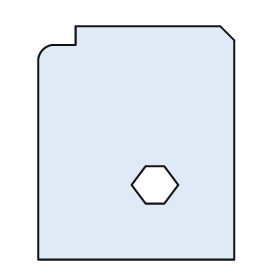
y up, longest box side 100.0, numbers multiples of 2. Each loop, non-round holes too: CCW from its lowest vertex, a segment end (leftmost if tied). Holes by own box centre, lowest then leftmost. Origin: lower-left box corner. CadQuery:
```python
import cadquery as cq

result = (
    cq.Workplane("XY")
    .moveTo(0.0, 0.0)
    .lineTo(84.0, 0.0)
    .lineTo(84.0, 94.0)
    .lineTo(78.0, 100.0)
    .lineTo(16.0, 100.0)
    .lineTo(16.0, 92.0)
    .lineTo(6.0, 92.0)
    .threePointArc((2.0, 90.0), (0.0, 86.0))
    .close()
    .moveTo(46.0, 24.0)
    .lineTo(54.0, 24.0)
    .lineTo(60.0, 32.0)
    .lineTo(54.0, 40.0)
    .lineTo(46.0, 40.0)
    .lineTo(40.0, 32.0)
    .close()
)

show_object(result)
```